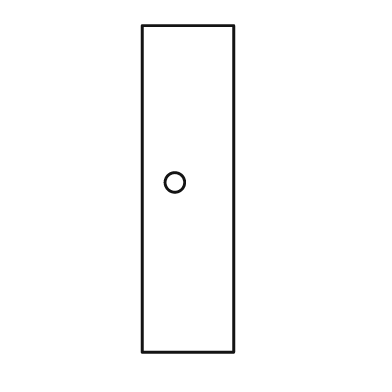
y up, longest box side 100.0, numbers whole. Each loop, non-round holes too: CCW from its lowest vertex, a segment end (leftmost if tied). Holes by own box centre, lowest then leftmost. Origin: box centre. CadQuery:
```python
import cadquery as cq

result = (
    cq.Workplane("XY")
    .moveTo(-14.0, -50.0)
    .lineTo(14.0, -50.0)
    .lineTo(14.0, 50.0)
    .lineTo(-14.0, 50.0)
    .close()
    .moveTo(-4.0, 2.0)
    .circle(3.0)
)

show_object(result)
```